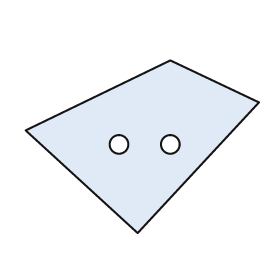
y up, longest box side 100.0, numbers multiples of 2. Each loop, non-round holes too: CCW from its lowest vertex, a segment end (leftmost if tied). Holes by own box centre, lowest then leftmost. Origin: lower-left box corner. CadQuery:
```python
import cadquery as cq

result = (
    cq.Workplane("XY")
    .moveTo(48.0, 0.0)
    .lineTo(100.0, 56.0)
    .lineTo(62.0, 74.0)
    .lineTo(0.0, 44.0)
    .close()
    .moveTo(40.0, 38.0)
    .circle(4.0)
    .moveTo(62.0, 38.0)
    .circle(4.0)
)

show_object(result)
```